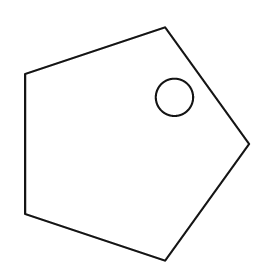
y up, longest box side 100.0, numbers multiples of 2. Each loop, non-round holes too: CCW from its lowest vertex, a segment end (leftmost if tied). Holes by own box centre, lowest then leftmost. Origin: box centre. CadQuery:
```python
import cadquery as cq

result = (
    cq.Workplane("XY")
    .moveTo(12.0, -50.0)
    .lineTo(48.0, 0.0)
    .lineTo(12.0, 50.0)
    .lineTo(-48.0, 30.0)
    .lineTo(-48.0, -30.0)
    .close()
    .moveTo(16.0, 20.0)
    .circle(8.0)
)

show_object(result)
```